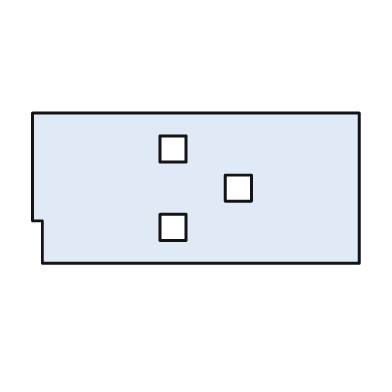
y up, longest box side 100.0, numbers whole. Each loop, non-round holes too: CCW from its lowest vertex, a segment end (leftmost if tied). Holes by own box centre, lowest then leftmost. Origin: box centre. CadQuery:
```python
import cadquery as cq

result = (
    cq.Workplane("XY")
    .moveTo(-47.0, -23.0)
    .lineTo(50.0, -23.0)
    .lineTo(50.0, 23.0)
    .lineTo(-50.0, 23.0)
    .lineTo(-50.0, -10.0)
    .lineTo(-47.0, -10.0)
    .close()
    .moveTo(-11.0, -16.0)
    .lineTo(-3.0, -16.0)
    .lineTo(-3.0, -8.0)
    .lineTo(-11.0, -8.0)
    .close()
    .moveTo(9.0, -4.0)
    .lineTo(17.0, -4.0)
    .lineTo(17.0, 4.0)
    .lineTo(9.0, 4.0)
    .close()
    .moveTo(-11.0, 8.0)
    .lineTo(-3.0, 8.0)
    .lineTo(-3.0, 16.0)
    .lineTo(-11.0, 16.0)
    .close()
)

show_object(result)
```